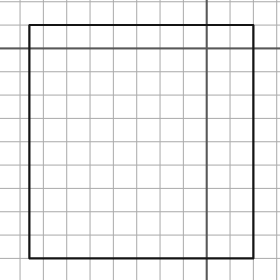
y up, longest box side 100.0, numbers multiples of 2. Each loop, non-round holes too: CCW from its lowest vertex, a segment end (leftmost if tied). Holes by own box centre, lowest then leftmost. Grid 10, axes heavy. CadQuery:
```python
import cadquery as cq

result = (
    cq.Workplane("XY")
    .moveTo(-76.0, -90.0)
    .lineTo(20.0, -90.0)
    .lineTo(20.0, 10.0)
    .lineTo(-76.0, 10.0)
    .close()
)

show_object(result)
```